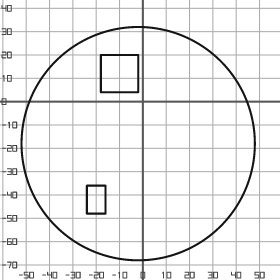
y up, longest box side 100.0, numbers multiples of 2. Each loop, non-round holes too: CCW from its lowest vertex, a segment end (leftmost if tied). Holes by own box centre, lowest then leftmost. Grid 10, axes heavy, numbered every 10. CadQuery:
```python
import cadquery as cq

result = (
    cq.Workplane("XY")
    .moveTo(-2.0, -18.0)
    .circle(50.0)
    .moveTo(-24.0, -48.0)
    .lineTo(-16.0, -48.0)
    .lineTo(-16.0, -36.0)
    .lineTo(-24.0, -36.0)
    .close()
    .moveTo(-18.0, 4.0)
    .lineTo(-2.0, 4.0)
    .lineTo(-2.0, 20.0)
    .lineTo(-18.0, 20.0)
    .close()
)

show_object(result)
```